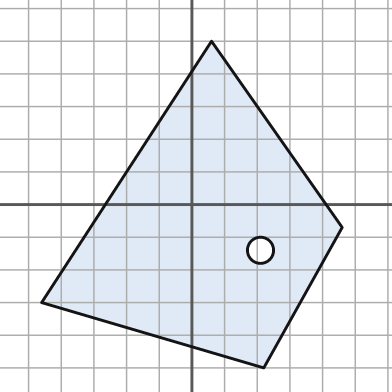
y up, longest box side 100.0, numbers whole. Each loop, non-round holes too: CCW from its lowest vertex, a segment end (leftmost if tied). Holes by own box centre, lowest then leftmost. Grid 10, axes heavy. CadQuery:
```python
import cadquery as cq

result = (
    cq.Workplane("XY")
    .moveTo(22.0, -50.0)
    .lineTo(46.0, -7.0)
    .lineTo(6.0, 50.0)
    .lineTo(-46.0, -30.0)
    .close()
    .moveTo(21.0, -14.0)
    .circle(4.0)
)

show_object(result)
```